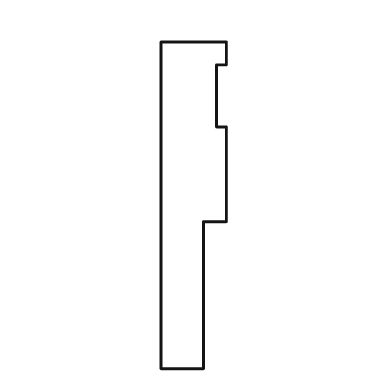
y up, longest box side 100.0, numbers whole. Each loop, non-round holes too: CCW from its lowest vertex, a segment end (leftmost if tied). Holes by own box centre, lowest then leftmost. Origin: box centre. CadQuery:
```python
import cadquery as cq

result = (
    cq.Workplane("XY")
    .moveTo(-10.0, -50.0)
    .lineTo(3.0, -50.0)
    .lineTo(3.0, -5.0)
    .lineTo(10.0, -5.0)
    .lineTo(10.0, 24.0)
    .lineTo(7.0, 24.0)
    .lineTo(7.0, 43.0)
    .lineTo(10.0, 43.0)
    .lineTo(10.0, 50.0)
    .lineTo(-10.0, 50.0)
    .close()
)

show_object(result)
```